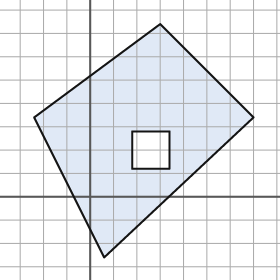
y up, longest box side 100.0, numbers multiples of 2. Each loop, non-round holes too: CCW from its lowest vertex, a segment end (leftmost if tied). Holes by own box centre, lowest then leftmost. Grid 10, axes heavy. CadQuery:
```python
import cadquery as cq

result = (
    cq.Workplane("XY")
    .moveTo(6.0, -26.0)
    .lineTo(70.0, 34.0)
    .lineTo(30.0, 74.0)
    .lineTo(-24.0, 34.0)
    .close()
    .moveTo(18.0, 12.0)
    .lineTo(34.0, 12.0)
    .lineTo(34.0, 28.0)
    .lineTo(18.0, 28.0)
    .close()
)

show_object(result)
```